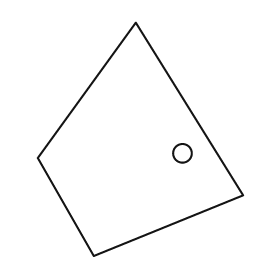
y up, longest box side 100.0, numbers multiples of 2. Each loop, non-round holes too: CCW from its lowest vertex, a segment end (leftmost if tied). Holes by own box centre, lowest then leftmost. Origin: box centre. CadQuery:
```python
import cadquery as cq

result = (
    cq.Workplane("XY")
    .moveTo(-20.0, -50.0)
    .lineTo(44.0, -24.0)
    .lineTo(-2.0, 50.0)
    .lineTo(-44.0, -8.0)
    .close()
    .moveTo(18.0, -6.0)
    .circle(4.0)
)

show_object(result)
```